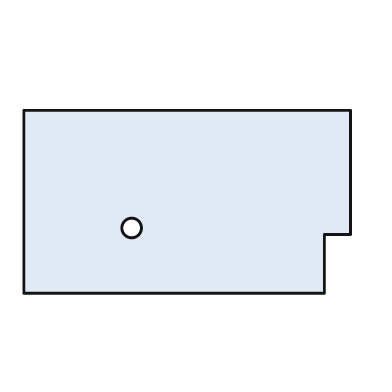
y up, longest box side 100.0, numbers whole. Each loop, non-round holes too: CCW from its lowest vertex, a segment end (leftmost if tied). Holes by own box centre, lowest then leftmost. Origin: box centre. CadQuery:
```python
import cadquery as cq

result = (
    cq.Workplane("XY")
    .moveTo(-50.0, -28.0)
    .lineTo(42.0, -28.0)
    .lineTo(42.0, -10.0)
    .lineTo(50.0, -10.0)
    .lineTo(50.0, 28.0)
    .lineTo(-50.0, 28.0)
    .close()
    .moveTo(-17.0, -8.0)
    .circle(3.0)
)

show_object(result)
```